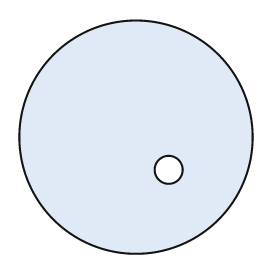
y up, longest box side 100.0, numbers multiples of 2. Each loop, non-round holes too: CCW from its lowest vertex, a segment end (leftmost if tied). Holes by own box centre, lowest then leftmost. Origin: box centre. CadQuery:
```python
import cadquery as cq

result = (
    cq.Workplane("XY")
    .moveTo(0.0, 0.0)
    .circle(50.0)
    .moveTo(14.0, -14.0)
    .circle(6.0)
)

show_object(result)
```